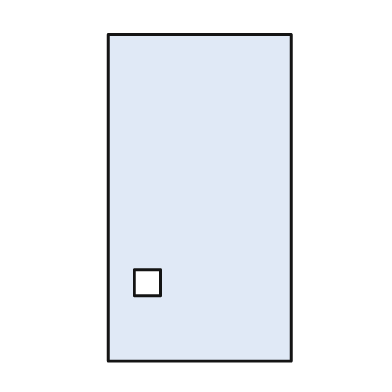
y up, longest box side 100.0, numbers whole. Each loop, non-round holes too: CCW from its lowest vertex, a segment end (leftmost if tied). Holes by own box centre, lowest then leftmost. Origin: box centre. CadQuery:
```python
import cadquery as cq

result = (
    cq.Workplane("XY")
    .moveTo(-28.0, -50.0)
    .lineTo(28.0, -50.0)
    .lineTo(28.0, 50.0)
    .lineTo(-28.0, 50.0)
    .close()
    .moveTo(-20.0, -30.0)
    .lineTo(-12.0, -30.0)
    .lineTo(-12.0, -22.0)
    .lineTo(-20.0, -22.0)
    .close()
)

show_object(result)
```